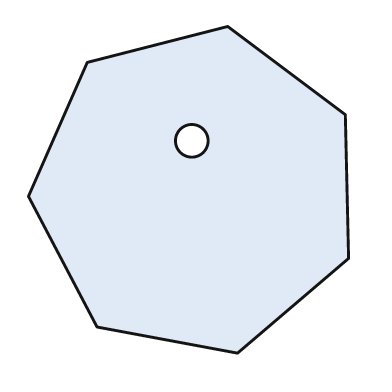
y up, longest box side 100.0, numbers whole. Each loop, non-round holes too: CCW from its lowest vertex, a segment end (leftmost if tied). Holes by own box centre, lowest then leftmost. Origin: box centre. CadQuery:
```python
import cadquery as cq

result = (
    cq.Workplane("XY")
    .moveTo(15.0, -50.0)
    .lineTo(49.0, -21.0)
    .lineTo(48.0, 23.0)
    .lineTo(12.0, 50.0)
    .lineTo(-31.0, 39.0)
    .lineTo(-49.0, -2.0)
    .lineTo(-28.0, -42.0)
    .close()
    .moveTo(1.0, 15.0)
    .circle(5.0)
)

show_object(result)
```